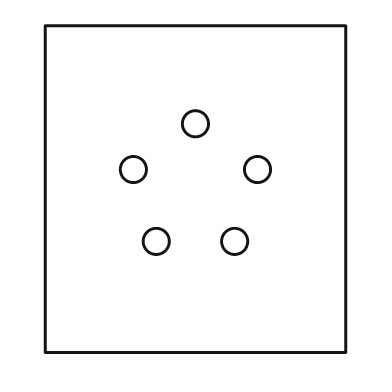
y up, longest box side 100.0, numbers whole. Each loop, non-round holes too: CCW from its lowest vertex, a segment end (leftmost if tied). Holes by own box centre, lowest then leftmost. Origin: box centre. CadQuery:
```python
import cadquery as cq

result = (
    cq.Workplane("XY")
    .moveTo(-46.0, -50.0)
    .lineTo(46.0, -50.0)
    .lineTo(46.0, 50.0)
    .lineTo(-46.0, 50.0)
    .close()
    .moveTo(-12.0, -16.0)
    .circle(4.0)
    .moveTo(12.0, -16.0)
    .circle(4.0)
    .moveTo(-19.0, 6.0)
    .circle(4.0)
    .moveTo(19.0, 6.0)
    .circle(4.0)
    .moveTo(0.0, 20.0)
    .circle(4.0)
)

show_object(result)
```